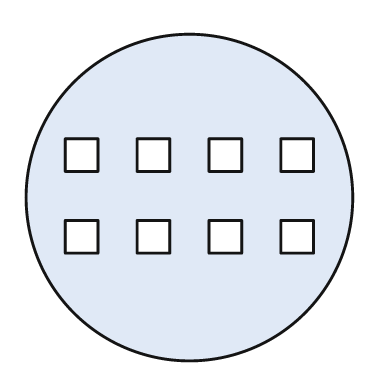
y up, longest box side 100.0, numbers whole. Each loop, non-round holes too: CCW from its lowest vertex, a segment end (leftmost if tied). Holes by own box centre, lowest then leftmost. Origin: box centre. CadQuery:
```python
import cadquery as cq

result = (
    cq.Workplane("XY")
    .moveTo(0.0, 0.0)
    .circle(50.0)
    .moveTo(-38.0, -17.0)
    .lineTo(-28.0, -17.0)
    .lineTo(-28.0, -7.0)
    .lineTo(-38.0, -7.0)
    .close()
    .moveTo(-16.0, -17.0)
    .lineTo(-6.0, -17.0)
    .lineTo(-6.0, -7.0)
    .lineTo(-16.0, -7.0)
    .close()
    .moveTo(6.0, -17.0)
    .lineTo(16.0, -17.0)
    .lineTo(16.0, -7.0)
    .lineTo(6.0, -7.0)
    .close()
    .moveTo(28.0, -17.0)
    .lineTo(38.0, -17.0)
    .lineTo(38.0, -7.0)
    .lineTo(28.0, -7.0)
    .close()
    .moveTo(-38.0, 8.0)
    .lineTo(-28.0, 8.0)
    .lineTo(-28.0, 18.0)
    .lineTo(-38.0, 18.0)
    .close()
    .moveTo(-16.0, 8.0)
    .lineTo(-6.0, 8.0)
    .lineTo(-6.0, 18.0)
    .lineTo(-16.0, 18.0)
    .close()
    .moveTo(6.0, 8.0)
    .lineTo(16.0, 8.0)
    .lineTo(16.0, 18.0)
    .lineTo(6.0, 18.0)
    .close()
    .moveTo(28.0, 8.0)
    .lineTo(38.0, 8.0)
    .lineTo(38.0, 18.0)
    .lineTo(28.0, 18.0)
    .close()
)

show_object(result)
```